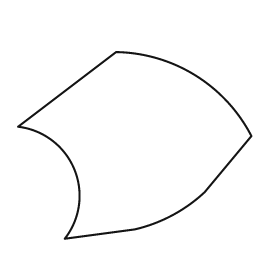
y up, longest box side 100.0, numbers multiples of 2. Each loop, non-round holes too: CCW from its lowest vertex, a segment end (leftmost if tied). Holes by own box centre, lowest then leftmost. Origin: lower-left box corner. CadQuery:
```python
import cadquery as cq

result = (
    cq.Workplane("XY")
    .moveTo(20.0, 0.0)
    .lineTo(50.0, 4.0)
    .threePointArc((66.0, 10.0), (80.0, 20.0))
    .lineTo(100.0, 44.0)
    .threePointArc((76.0, 70.0), (42.0, 80.0))
    .lineTo(0.0, 48.0)
    .threePointArc((24.0, 30.0), (20.0, 0.0))
    .close()
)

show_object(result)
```